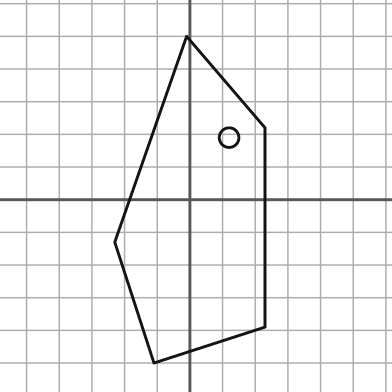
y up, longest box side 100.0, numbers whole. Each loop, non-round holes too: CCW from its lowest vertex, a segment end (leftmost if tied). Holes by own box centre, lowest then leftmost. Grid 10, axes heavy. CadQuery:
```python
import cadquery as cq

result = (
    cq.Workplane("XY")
    .moveTo(-11.0, -50.0)
    .lineTo(23.0, -39.0)
    .lineTo(23.0, 22.0)
    .lineTo(-1.0, 50.0)
    .lineTo(-23.0, -13.0)
    .close()
    .moveTo(12.0, 19.0)
    .circle(3.0)
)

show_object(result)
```